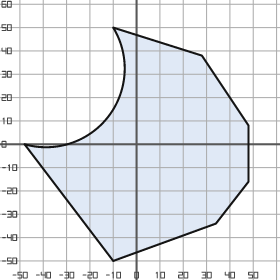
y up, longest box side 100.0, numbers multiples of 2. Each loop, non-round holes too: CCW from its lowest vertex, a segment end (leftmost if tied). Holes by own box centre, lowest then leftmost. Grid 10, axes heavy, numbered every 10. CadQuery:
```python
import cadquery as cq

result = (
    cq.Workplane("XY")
    .moveTo(-10.0, -50.0)
    .lineTo(34.0, -34.0)
    .lineTo(48.0, -16.0)
    .lineTo(48.0, 8.0)
    .lineTo(28.0, 38.0)
    .lineTo(-10.0, 50.0)
    .threePointArc((-12.0, 12.0), (-48.0, 0.0))
    .close()
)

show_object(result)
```